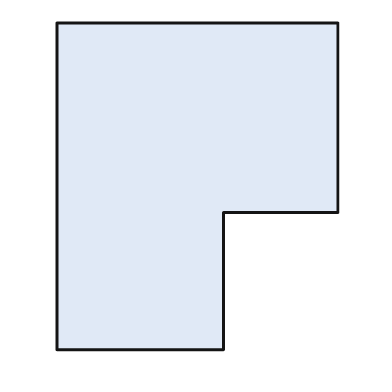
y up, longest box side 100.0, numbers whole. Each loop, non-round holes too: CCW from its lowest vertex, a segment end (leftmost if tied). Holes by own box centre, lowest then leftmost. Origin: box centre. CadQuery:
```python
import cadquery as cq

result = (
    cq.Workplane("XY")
    .moveTo(-43.0, -50.0)
    .lineTo(8.0, -50.0)
    .lineTo(8.0, -8.0)
    .lineTo(43.0, -8.0)
    .lineTo(43.0, 50.0)
    .lineTo(-43.0, 50.0)
    .close()
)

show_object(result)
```